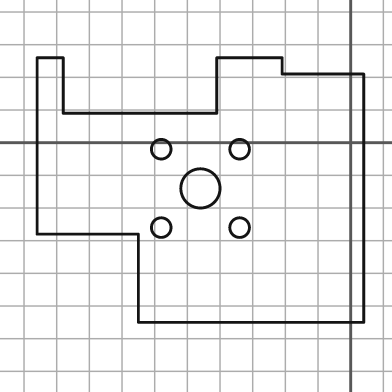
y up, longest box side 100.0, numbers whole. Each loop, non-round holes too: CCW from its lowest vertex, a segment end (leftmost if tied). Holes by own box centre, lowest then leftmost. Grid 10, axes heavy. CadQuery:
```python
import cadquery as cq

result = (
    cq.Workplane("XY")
    .moveTo(-65.0, -55.0)
    .lineTo(4.0, -55.0)
    .lineTo(4.0, 21.0)
    .lineTo(-21.0, 21.0)
    .lineTo(-21.0, 26.0)
    .lineTo(-41.0, 26.0)
    .lineTo(-41.0, 9.0)
    .lineTo(-88.0, 9.0)
    .lineTo(-88.0, 26.0)
    .lineTo(-96.0, 26.0)
    .lineTo(-96.0, -28.0)
    .lineTo(-65.0, -28.0)
    .close()
    .moveTo(-58.0, -26.0)
    .circle(3.0)
    .moveTo(-34.0, -26.0)
    .circle(3.0)
    .moveTo(-46.0, -14.0)
    .circle(6.0)
    .moveTo(-58.0, -2.0)
    .circle(3.0)
    .moveTo(-34.0, -2.0)
    .circle(3.0)
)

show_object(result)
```